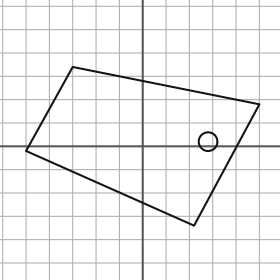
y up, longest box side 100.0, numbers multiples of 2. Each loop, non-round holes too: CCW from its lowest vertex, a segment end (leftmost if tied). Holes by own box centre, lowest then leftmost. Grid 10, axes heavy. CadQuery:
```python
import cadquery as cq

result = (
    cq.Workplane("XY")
    .moveTo(22.0, -34.0)
    .lineTo(50.0, 18.0)
    .lineTo(-30.0, 34.0)
    .lineTo(-50.0, -2.0)
    .close()
    .moveTo(28.0, 2.0)
    .circle(4.0)
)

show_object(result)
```